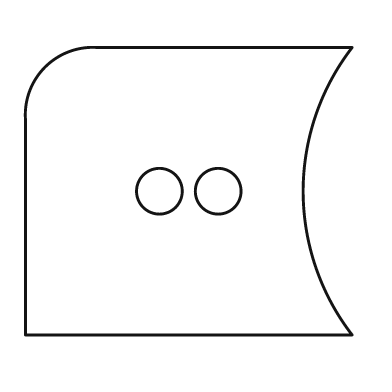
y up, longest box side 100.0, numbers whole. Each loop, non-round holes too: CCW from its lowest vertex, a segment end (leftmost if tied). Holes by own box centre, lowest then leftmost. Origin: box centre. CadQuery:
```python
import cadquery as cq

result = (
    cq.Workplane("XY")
    .moveTo(-50.0, -44.0)
    .lineTo(50.0, -44.0)
    .threePointArc((35.0, 0.0), (50.0, 44.0))
    .lineTo(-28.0, 44.0)
    .threePointArc((-44.0, 38.0), (-50.0, 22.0))
    .close()
    .moveTo(-9.0, 0.0)
    .circle(7.0)
    .moveTo(9.0, 0.0)
    .circle(7.0)
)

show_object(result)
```